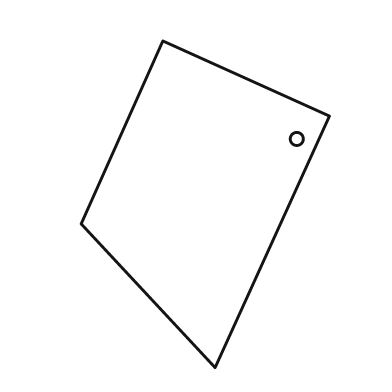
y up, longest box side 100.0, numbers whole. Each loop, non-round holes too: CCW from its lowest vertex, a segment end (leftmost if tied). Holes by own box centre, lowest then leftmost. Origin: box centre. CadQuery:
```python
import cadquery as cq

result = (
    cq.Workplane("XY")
    .moveTo(3.0, -50.0)
    .lineTo(38.0, 27.0)
    .lineTo(-13.0, 50.0)
    .lineTo(-38.0, -6.0)
    .close()
    .moveTo(28.0, 20.0)
    .circle(2.0)
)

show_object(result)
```